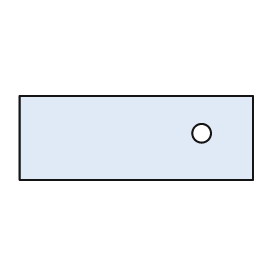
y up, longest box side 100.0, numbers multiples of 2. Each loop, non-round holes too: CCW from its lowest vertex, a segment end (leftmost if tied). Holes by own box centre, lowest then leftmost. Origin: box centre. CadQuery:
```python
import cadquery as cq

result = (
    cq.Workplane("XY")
    .moveTo(-50.0, -18.0)
    .lineTo(50.0, -18.0)
    .lineTo(50.0, 18.0)
    .lineTo(-50.0, 18.0)
    .close()
    .moveTo(28.0, 2.0)
    .circle(4.0)
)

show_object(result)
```